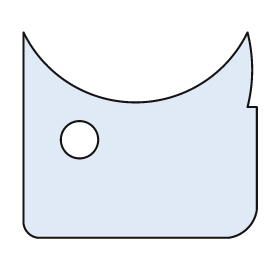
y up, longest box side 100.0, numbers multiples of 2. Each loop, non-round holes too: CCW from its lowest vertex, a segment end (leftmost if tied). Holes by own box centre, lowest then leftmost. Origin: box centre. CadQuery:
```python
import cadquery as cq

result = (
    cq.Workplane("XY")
    .moveTo(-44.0, -44.0)
    .lineTo(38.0, -44.0)
    .threePointArc((46.0, -40.0), (50.0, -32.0))
    .lineTo(50.0, 12.0)
    .lineTo(46.0, 12.0)
    .threePointArc((48.0, 28.0), (46.0, 44.0))
    .threePointArc((-2.0, 14.0), (-50.0, 44.0))
    .lineTo(-50.0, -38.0)
    .threePointArc((-48.0, -42.0), (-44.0, -44.0))
    .close()
    .moveTo(-26.0, -2.0)
    .circle(8.0)
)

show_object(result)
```